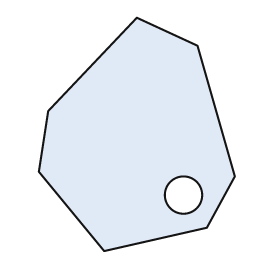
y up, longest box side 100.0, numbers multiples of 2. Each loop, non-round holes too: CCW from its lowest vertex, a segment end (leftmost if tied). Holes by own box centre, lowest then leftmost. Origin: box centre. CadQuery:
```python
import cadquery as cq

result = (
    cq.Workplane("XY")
    .moveTo(-14.0, -50.0)
    .lineTo(30.0, -40.0)
    .lineTo(42.0, -18.0)
    .lineTo(26.0, 38.0)
    .lineTo(0.0, 50.0)
    .lineTo(-38.0, 10.0)
    .lineTo(-42.0, -16.0)
    .close()
    .moveTo(20.0, -26.0)
    .circle(8.0)
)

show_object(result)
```